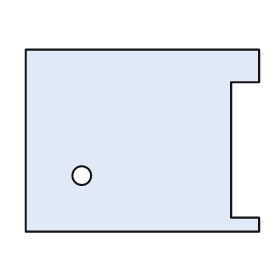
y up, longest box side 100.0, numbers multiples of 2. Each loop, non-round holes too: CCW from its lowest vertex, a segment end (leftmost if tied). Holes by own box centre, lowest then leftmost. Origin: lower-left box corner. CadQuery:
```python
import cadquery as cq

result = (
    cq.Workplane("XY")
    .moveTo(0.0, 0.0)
    .lineTo(100.0, 0.0)
    .lineTo(100.0, 6.0)
    .lineTo(88.0, 6.0)
    .lineTo(88.0, 64.0)
    .lineTo(100.0, 64.0)
    .lineTo(100.0, 78.0)
    .lineTo(0.0, 78.0)
    .close()
    .moveTo(24.0, 24.0)
    .circle(4.0)
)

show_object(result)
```